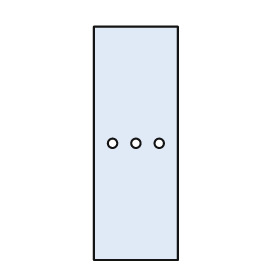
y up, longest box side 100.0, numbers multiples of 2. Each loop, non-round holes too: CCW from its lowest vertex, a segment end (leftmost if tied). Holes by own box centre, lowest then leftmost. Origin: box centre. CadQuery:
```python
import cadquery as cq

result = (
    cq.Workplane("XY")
    .moveTo(-18.0, -50.0)
    .lineTo(18.0, -50.0)
    .lineTo(18.0, 50.0)
    .lineTo(-18.0, 50.0)
    .close()
    .moveTo(-10.0, 0.0)
    .circle(2.0)
    .moveTo(0.0, 0.0)
    .circle(2.0)
    .moveTo(10.0, 0.0)
    .circle(2.0)
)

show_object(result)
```